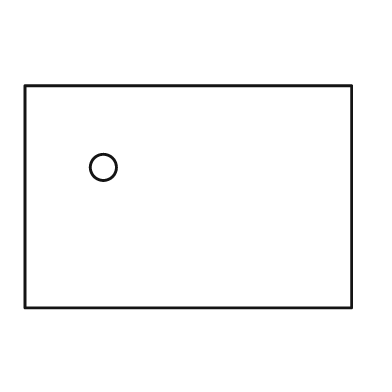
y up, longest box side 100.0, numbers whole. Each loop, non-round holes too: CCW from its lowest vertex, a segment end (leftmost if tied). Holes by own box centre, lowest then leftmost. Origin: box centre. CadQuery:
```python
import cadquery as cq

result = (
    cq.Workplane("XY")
    .moveTo(-50.0, -34.0)
    .lineTo(50.0, -34.0)
    .lineTo(50.0, 34.0)
    .lineTo(-50.0, 34.0)
    .close()
    .moveTo(-26.0, 9.0)
    .circle(4.0)
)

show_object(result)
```